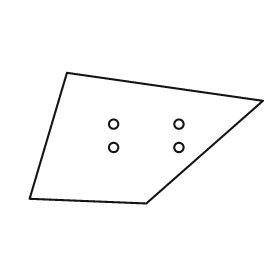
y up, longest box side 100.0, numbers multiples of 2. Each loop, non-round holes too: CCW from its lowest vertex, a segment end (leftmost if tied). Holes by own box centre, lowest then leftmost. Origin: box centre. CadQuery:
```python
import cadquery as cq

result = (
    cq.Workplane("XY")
    .moveTo(0.0, -28.0)
    .lineTo(50.0, 16.0)
    .lineTo(-34.0, 28.0)
    .lineTo(-50.0, -26.0)
    .close()
    .moveTo(-14.0, -4.0)
    .circle(2.0)
    .moveTo(14.0, -4.0)
    .circle(2.0)
    .moveTo(-14.0, 6.0)
    .circle(2.0)
    .moveTo(14.0, 6.0)
    .circle(2.0)
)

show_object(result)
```